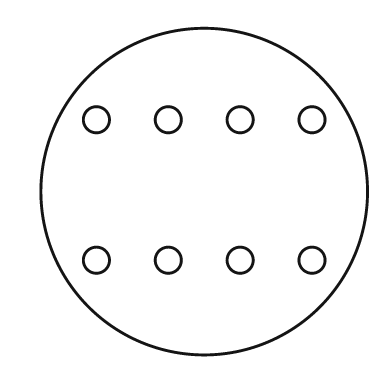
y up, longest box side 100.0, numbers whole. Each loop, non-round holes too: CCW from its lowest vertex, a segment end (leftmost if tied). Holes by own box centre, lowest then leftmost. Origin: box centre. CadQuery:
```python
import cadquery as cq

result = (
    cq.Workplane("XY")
    .moveTo(0.0, 0.0)
    .circle(50.0)
    .moveTo(-33.0, -21.0)
    .circle(4.0)
    .moveTo(-11.0, -21.0)
    .circle(4.0)
    .moveTo(11.0, -21.0)
    .circle(4.0)
    .moveTo(33.0, -21.0)
    .circle(4.0)
    .moveTo(-33.0, 22.0)
    .circle(4.0)
    .moveTo(-11.0, 22.0)
    .circle(4.0)
    .moveTo(11.0, 22.0)
    .circle(4.0)
    .moveTo(33.0, 22.0)
    .circle(4.0)
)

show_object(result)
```